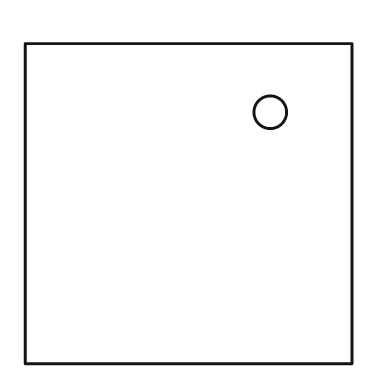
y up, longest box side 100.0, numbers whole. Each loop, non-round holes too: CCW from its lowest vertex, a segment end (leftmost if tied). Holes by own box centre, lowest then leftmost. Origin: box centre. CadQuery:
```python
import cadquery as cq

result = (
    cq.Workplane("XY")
    .moveTo(-50.0, -49.0)
    .lineTo(50.0, -49.0)
    .lineTo(50.0, 49.0)
    .lineTo(-50.0, 49.0)
    .close()
    .moveTo(25.0, 28.0)
    .circle(5.0)
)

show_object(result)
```